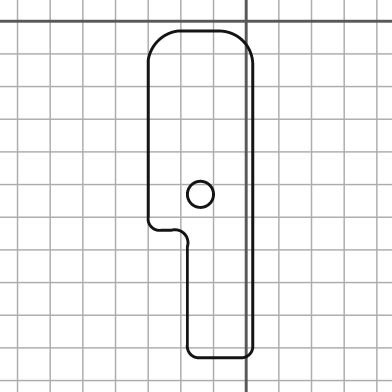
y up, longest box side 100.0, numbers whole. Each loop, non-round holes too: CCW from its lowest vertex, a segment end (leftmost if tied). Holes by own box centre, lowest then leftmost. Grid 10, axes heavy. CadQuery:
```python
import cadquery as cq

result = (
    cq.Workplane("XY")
    .moveTo(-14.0, -103.0)
    .lineTo(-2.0, -103.0)
    .threePointArc((1.0, -102.0), (2.0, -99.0))
    .lineTo(2.0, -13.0)
    .threePointArc((-1.0, -6.0), (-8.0, -3.0))
    .lineTo(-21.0, -3.0)
    .threePointArc((-27.0, -6.0), (-30.0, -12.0))
    .lineTo(-30.0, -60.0)
    .threePointArc((-29.0, -63.0), (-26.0, -64.0))
    .lineTo(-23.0, -64.0)
    .threePointArc((-19.0, -65.0), (-18.0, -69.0))
    .lineTo(-18.0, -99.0)
    .threePointArc((-17.0, -102.0), (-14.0, -103.0))
    .close()
    .moveTo(-14.0, -53.0)
    .circle(4.0)
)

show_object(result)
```